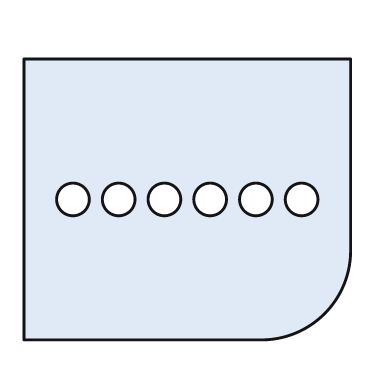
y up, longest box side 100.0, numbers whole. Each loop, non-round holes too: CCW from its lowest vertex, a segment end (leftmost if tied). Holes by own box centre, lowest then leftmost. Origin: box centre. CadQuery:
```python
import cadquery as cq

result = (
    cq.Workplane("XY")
    .moveTo(-50.0, -43.0)
    .lineTo(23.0, -43.0)
    .threePointArc((42.0, -35.0), (50.0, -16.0))
    .lineTo(50.0, 43.0)
    .lineTo(-50.0, 43.0)
    .close()
    .moveTo(-35.0, 0.0)
    .circle(5.0)
    .moveTo(-21.0, 0.0)
    .circle(5.0)
    .moveTo(-7.0, 0.0)
    .circle(5.0)
    .moveTo(7.0, 0.0)
    .circle(5.0)
    .moveTo(21.0, 0.0)
    .circle(5.0)
    .moveTo(35.0, 0.0)
    .circle(5.0)
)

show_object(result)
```